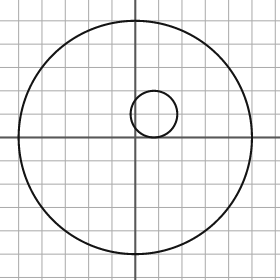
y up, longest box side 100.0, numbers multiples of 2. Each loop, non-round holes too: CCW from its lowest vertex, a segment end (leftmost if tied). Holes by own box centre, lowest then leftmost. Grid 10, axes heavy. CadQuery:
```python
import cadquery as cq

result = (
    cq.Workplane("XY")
    .moveTo(0.0, 0.0)
    .circle(50.0)
    .moveTo(8.0, 10.0)
    .circle(10.0)
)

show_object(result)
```